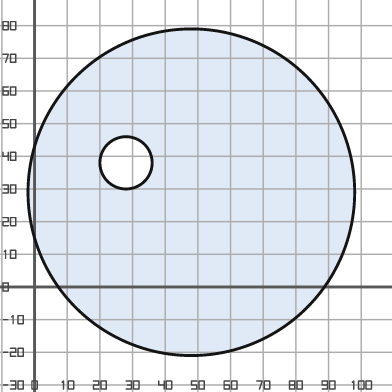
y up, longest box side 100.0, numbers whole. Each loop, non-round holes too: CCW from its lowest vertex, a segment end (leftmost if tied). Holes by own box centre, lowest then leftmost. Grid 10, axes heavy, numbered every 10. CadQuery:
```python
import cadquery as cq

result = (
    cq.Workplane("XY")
    .moveTo(48.0, 29.0)
    .circle(50.0)
    .moveTo(28.0, 38.0)
    .circle(8.0)
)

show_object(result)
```